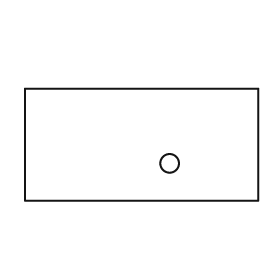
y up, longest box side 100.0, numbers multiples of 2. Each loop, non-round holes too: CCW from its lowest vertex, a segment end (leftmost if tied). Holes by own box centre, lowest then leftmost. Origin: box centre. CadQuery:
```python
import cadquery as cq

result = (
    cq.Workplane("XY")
    .moveTo(-50.0, -24.0)
    .lineTo(50.0, -24.0)
    .lineTo(50.0, 24.0)
    .lineTo(-50.0, 24.0)
    .close()
    .moveTo(12.0, -8.0)
    .circle(4.0)
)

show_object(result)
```